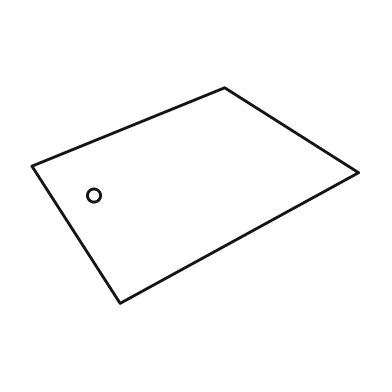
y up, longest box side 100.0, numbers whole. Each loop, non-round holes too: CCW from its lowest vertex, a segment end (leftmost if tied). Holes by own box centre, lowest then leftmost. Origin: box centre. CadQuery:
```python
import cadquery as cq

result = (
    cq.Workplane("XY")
    .moveTo(-23.0, -33.0)
    .lineTo(50.0, 7.0)
    .lineTo(9.0, 33.0)
    .lineTo(-50.0, 9.0)
    .close()
    .moveTo(-31.0, 0.0)
    .circle(2.0)
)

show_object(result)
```